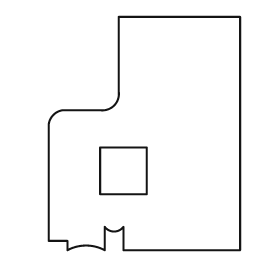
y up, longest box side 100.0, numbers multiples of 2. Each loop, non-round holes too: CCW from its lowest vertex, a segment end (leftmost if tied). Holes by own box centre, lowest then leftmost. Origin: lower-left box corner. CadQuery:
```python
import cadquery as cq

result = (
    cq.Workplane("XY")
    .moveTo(8.0, 0.0)
    .threePointArc((16.0, 2.0), (24.0, 0.0))
    .lineTo(24.0, 10.0)
    .threePointArc((28.0, 8.0), (32.0, 10.0))
    .lineTo(32.0, 0.0)
    .lineTo(82.0, 0.0)
    .lineTo(82.0, 100.0)
    .lineTo(30.0, 100.0)
    .lineTo(30.0, 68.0)
    .threePointArc((28.0, 62.0), (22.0, 60.0))
    .lineTo(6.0, 60.0)
    .threePointArc((2.0, 58.0), (0.0, 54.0))
    .lineTo(0.0, 4.0)
    .lineTo(8.0, 4.0)
    .close()
    .moveTo(22.0, 24.0)
    .lineTo(42.0, 24.0)
    .lineTo(42.0, 44.0)
    .lineTo(22.0, 44.0)
    .close()
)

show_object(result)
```